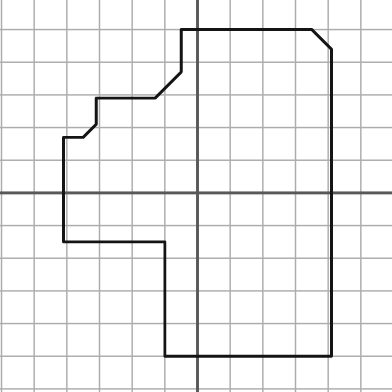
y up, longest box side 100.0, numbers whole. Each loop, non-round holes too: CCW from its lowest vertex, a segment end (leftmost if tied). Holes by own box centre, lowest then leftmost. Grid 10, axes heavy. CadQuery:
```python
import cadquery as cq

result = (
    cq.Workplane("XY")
    .moveTo(-10.0, -50.0)
    .lineTo(41.0, -50.0)
    .lineTo(41.0, 44.0)
    .lineTo(35.0, 50.0)
    .lineTo(-5.0, 50.0)
    .lineTo(-5.0, 37.0)
    .lineTo(-13.0, 29.0)
    .lineTo(-31.0, 29.0)
    .lineTo(-31.0, 21.0)
    .lineTo(-35.0, 17.0)
    .lineTo(-41.0, 17.0)
    .lineTo(-41.0, -15.0)
    .lineTo(-10.0, -15.0)
    .close()
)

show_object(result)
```